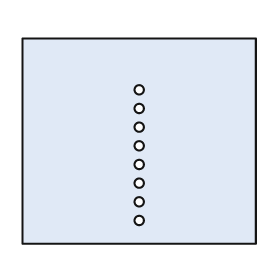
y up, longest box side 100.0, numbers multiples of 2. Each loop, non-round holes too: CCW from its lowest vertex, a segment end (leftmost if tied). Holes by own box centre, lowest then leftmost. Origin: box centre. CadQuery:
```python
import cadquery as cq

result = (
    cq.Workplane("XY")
    .moveTo(-50.0, -44.0)
    .lineTo(50.0, -44.0)
    .lineTo(50.0, 44.0)
    .lineTo(-50.0, 44.0)
    .close()
    .moveTo(0.0, -34.0)
    .circle(2.0)
    .moveTo(0.0, -26.0)
    .circle(2.0)
    .moveTo(0.0, -18.0)
    .circle(2.0)
    .moveTo(0.0, -10.0)
    .circle(2.0)
    .moveTo(0.0, -2.0)
    .circle(2.0)
    .moveTo(0.0, 6.0)
    .circle(2.0)
    .moveTo(0.0, 14.0)
    .circle(2.0)
    .moveTo(0.0, 22.0)
    .circle(2.0)
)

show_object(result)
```